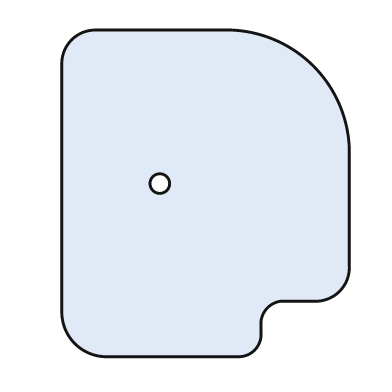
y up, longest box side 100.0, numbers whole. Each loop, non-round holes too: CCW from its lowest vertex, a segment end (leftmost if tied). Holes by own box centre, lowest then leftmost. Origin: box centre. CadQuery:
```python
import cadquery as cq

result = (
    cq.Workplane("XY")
    .moveTo(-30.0, -50.0)
    .lineTo(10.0, -50.0)
    .threePointArc((15.0, -48.0), (17.0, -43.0))
    .lineTo(17.0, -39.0)
    .threePointArc((19.0, -35.0), (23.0, -33.0))
    .lineTo(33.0, -33.0)
    .threePointArc((41.0, -30.0), (44.0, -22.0))
    .lineTo(44.0, 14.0)
    .threePointArc((33.0, 39.0), (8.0, 50.0))
    .lineTo(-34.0, 50.0)
    .threePointArc((-41.0, 47.0), (-44.0, 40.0))
    .lineTo(-44.0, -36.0)
    .threePointArc((-40.0, -46.0), (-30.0, -50.0))
    .close()
    .moveTo(-14.0, 3.0)
    .circle(3.0)
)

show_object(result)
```